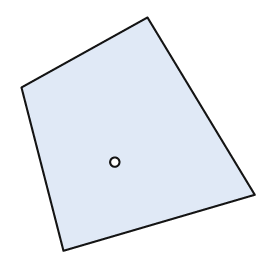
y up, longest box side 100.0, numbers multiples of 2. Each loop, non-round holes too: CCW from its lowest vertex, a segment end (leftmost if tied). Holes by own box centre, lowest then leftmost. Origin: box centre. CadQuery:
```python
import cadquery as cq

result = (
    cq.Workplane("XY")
    .moveTo(-32.0, -50.0)
    .lineTo(50.0, -26.0)
    .lineTo(4.0, 50.0)
    .lineTo(-50.0, 20.0)
    .close()
    .moveTo(-10.0, -12.0)
    .circle(2.0)
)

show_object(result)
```